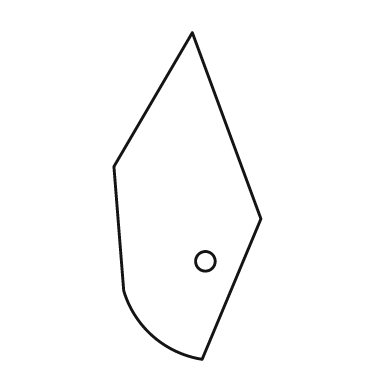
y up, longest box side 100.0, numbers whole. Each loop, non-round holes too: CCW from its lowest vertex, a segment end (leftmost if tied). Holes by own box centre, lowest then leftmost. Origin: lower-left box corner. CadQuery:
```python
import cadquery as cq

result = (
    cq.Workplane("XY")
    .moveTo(27.0, 0.0)
    .lineTo(45.0, 43.0)
    .lineTo(24.0, 100.0)
    .lineTo(0.0, 59.0)
    .lineTo(3.0, 21.0)
    .threePointArc((12.0, 7.0), (27.0, 0.0))
    .close()
    .moveTo(28.0, 30.0)
    .circle(3.0)
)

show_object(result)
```